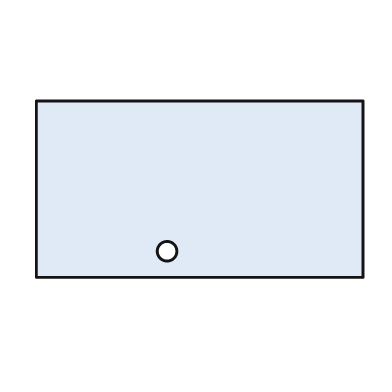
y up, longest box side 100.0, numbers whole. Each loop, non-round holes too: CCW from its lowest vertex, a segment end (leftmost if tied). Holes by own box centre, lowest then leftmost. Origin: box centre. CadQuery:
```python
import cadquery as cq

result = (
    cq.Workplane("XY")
    .moveTo(-50.0, -27.0)
    .lineTo(50.0, -27.0)
    .lineTo(50.0, 27.0)
    .lineTo(-50.0, 27.0)
    .close()
    .moveTo(-10.0, -19.0)
    .circle(3.0)
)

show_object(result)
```